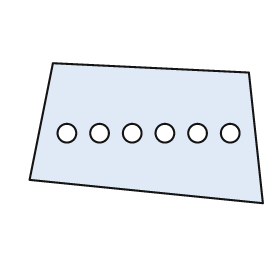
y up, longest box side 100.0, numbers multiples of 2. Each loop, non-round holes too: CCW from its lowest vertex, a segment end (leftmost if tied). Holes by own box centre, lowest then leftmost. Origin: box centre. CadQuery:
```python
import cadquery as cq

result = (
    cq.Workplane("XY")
    .moveTo(50.0, -30.0)
    .lineTo(44.0, 26.0)
    .lineTo(-40.0, 30.0)
    .lineTo(-50.0, -20.0)
    .close()
    .moveTo(-34.0, 0.0)
    .circle(4.0)
    .moveTo(-20.0, 0.0)
    .circle(4.0)
    .moveTo(-6.0, 0.0)
    .circle(4.0)
    .moveTo(8.0, 0.0)
    .circle(4.0)
    .moveTo(22.0, 0.0)
    .circle(4.0)
    .moveTo(36.0, 0.0)
    .circle(4.0)
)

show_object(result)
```